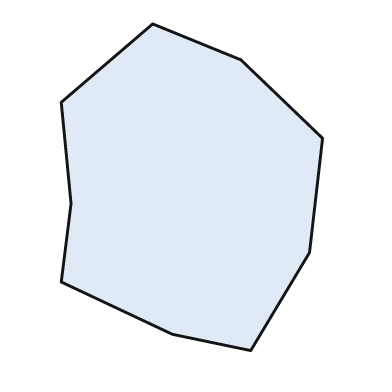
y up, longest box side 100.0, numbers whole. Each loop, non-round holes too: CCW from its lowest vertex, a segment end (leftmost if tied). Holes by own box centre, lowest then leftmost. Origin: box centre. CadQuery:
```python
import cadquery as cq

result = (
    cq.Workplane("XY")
    .moveTo(18.0, -50.0)
    .lineTo(36.0, -20.0)
    .lineTo(40.0, 15.0)
    .lineTo(15.0, 39.0)
    .lineTo(-12.0, 50.0)
    .lineTo(-40.0, 26.0)
    .lineTo(-37.0, -5.0)
    .lineTo(-40.0, -29.0)
    .lineTo(-6.0, -45.0)
    .close()
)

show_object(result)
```